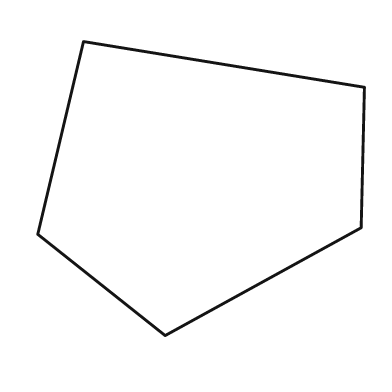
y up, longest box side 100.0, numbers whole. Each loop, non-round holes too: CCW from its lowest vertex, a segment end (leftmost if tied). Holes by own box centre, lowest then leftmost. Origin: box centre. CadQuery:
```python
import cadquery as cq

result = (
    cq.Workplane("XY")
    .moveTo(-11.0, -45.0)
    .lineTo(49.0, -12.0)
    .lineTo(50.0, 31.0)
    .lineTo(-36.0, 45.0)
    .lineTo(-50.0, -14.0)
    .close()
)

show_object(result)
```